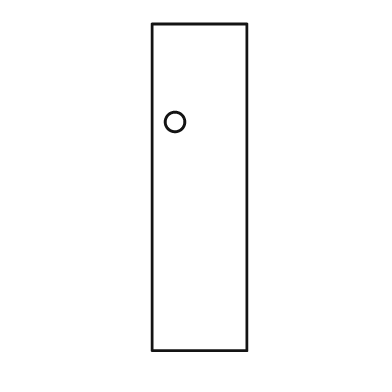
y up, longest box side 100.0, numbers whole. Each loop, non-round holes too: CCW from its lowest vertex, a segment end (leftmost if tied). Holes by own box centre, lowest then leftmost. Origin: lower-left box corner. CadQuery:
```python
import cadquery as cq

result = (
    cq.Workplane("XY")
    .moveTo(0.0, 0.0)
    .lineTo(29.0, 0.0)
    .lineTo(29.0, 100.0)
    .lineTo(0.0, 100.0)
    .close()
    .moveTo(7.0, 70.0)
    .circle(3.0)
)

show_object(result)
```